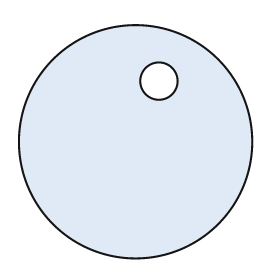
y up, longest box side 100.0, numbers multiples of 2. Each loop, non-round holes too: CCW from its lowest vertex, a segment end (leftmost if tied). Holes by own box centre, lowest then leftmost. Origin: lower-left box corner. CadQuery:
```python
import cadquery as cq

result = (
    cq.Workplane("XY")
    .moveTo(50.0, 50.0)
    .circle(50.0)
    .moveTo(60.0, 76.0)
    .circle(8.0)
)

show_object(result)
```